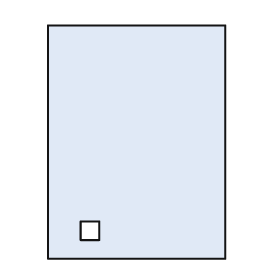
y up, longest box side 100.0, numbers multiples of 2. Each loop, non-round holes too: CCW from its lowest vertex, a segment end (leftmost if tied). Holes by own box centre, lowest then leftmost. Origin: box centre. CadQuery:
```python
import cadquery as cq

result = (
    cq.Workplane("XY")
    .moveTo(-38.0, -50.0)
    .lineTo(38.0, -50.0)
    .lineTo(38.0, 50.0)
    .lineTo(-38.0, 50.0)
    .close()
    .moveTo(-24.0, -42.0)
    .lineTo(-16.0, -42.0)
    .lineTo(-16.0, -34.0)
    .lineTo(-24.0, -34.0)
    .close()
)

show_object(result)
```